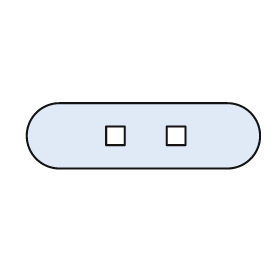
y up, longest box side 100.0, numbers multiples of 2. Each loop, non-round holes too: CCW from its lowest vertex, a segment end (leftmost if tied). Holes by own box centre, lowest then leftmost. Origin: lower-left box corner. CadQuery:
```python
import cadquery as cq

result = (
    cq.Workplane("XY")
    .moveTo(14.0, 0.0)
    .lineTo(86.0, 0.0)
    .threePointArc((100.0, 14.0), (86.0, 28.0))
    .lineTo(14.0, 28.0)
    .threePointArc((0.0, 14.0), (14.0, 0.0))
    .close()
    .moveTo(34.0, 10.0)
    .lineTo(42.0, 10.0)
    .lineTo(42.0, 18.0)
    .lineTo(34.0, 18.0)
    .close()
    .moveTo(60.0, 10.0)
    .lineTo(68.0, 10.0)
    .lineTo(68.0, 18.0)
    .lineTo(60.0, 18.0)
    .close()
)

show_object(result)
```